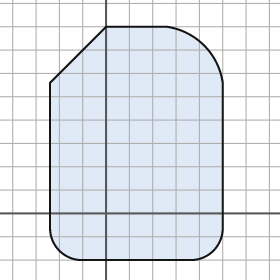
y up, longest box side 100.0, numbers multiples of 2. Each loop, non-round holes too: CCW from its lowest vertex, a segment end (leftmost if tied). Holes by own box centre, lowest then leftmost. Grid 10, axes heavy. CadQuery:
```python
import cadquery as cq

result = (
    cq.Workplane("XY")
    .moveTo(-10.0, -20.0)
    .lineTo(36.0, -20.0)
    .threePointArc((46.0, -16.0), (50.0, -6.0))
    .lineTo(50.0, 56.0)
    .threePointArc((42.0, 72.0), (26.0, 80.0))
    .lineTo(0.0, 80.0)
    .lineTo(-24.0, 56.0)
    .lineTo(-24.0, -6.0)
    .threePointArc((-20.0, -16.0), (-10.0, -20.0))
    .close()
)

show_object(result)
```